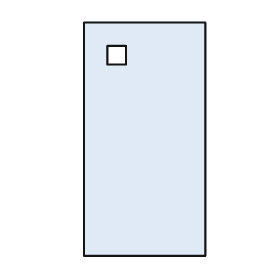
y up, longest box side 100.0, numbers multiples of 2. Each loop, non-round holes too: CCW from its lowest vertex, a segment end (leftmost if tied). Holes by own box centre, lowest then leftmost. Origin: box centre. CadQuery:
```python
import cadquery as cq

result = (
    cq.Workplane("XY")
    .moveTo(-26.0, -50.0)
    .lineTo(26.0, -50.0)
    .lineTo(26.0, 50.0)
    .lineTo(-26.0, 50.0)
    .close()
    .moveTo(-16.0, 32.0)
    .lineTo(-8.0, 32.0)
    .lineTo(-8.0, 40.0)
    .lineTo(-16.0, 40.0)
    .close()
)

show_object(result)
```